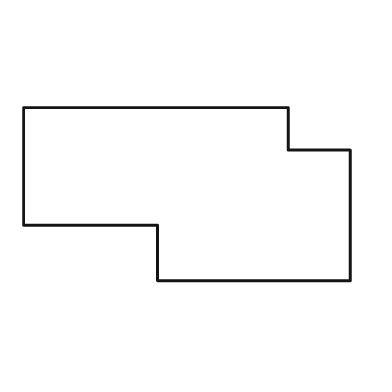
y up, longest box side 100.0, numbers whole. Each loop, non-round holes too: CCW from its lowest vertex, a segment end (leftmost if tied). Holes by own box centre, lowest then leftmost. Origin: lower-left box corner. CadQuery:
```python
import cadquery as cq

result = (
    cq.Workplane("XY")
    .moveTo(41.0, 0.0)
    .lineTo(100.0, 0.0)
    .lineTo(100.0, 40.0)
    .lineTo(81.0, 40.0)
    .lineTo(81.0, 53.0)
    .lineTo(0.0, 53.0)
    .lineTo(0.0, 17.0)
    .lineTo(41.0, 17.0)
    .close()
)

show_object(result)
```